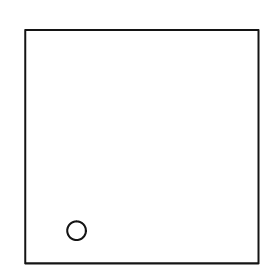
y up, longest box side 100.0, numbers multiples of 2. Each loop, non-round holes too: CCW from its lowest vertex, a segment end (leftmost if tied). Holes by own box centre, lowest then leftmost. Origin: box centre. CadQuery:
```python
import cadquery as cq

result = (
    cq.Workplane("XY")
    .moveTo(-50.0, -50.0)
    .lineTo(50.0, -50.0)
    .lineTo(50.0, 50.0)
    .lineTo(-50.0, 50.0)
    .close()
    .moveTo(-28.0, -36.0)
    .circle(4.0)
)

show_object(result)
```